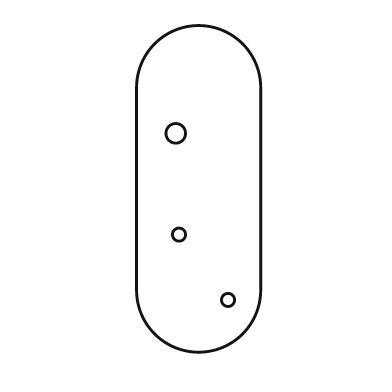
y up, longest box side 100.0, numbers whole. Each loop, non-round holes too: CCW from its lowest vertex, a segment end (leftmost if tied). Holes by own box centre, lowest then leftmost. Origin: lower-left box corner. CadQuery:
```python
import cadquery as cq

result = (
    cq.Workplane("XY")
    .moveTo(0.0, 19.0)
    .threePointArc((19.0, 0.0), (38.0, 19.0))
    .lineTo(38.0, 81.0)
    .threePointArc((19.0, 100.0), (0.0, 81.0))
    .close()
    .moveTo(28.0, 16.0)
    .circle(2.0)
    .moveTo(13.0, 36.0)
    .circle(2.0)
    .moveTo(12.0, 67.0)
    .circle(3.0)
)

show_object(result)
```